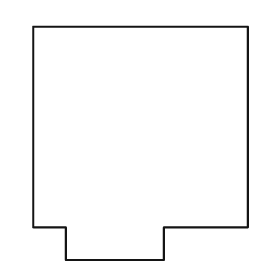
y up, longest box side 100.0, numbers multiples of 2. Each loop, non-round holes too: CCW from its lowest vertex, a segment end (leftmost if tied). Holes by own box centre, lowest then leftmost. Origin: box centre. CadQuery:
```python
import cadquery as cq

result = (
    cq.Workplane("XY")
    .moveTo(-32.0, -50.0)
    .lineTo(10.0, -50.0)
    .lineTo(10.0, -36.0)
    .lineTo(46.0, -36.0)
    .lineTo(46.0, 50.0)
    .lineTo(-46.0, 50.0)
    .lineTo(-46.0, -36.0)
    .lineTo(-32.0, -36.0)
    .close()
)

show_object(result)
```